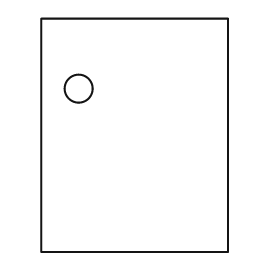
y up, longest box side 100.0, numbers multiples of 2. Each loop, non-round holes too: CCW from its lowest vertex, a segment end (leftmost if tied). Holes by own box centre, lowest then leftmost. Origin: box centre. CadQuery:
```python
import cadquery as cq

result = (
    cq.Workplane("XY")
    .moveTo(-40.0, -50.0)
    .lineTo(40.0, -50.0)
    .lineTo(40.0, 50.0)
    .lineTo(-40.0, 50.0)
    .close()
    .moveTo(-24.0, 20.0)
    .circle(6.0)
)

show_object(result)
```